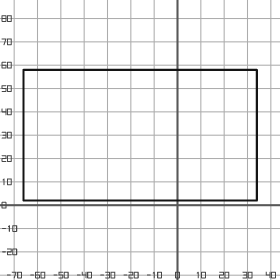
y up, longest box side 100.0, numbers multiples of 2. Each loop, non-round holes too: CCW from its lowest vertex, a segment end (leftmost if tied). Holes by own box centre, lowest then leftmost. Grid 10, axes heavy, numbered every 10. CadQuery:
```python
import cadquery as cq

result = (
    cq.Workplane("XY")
    .moveTo(-66.0, 2.0)
    .lineTo(34.0, 2.0)
    .lineTo(34.0, 58.0)
    .lineTo(-66.0, 58.0)
    .close()
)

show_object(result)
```